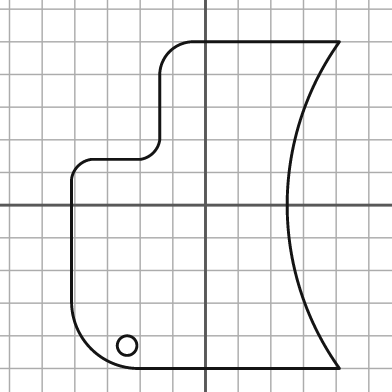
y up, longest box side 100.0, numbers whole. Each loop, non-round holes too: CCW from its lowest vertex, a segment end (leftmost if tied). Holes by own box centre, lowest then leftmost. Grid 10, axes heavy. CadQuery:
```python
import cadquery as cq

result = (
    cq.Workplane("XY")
    .moveTo(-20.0, -50.0)
    .lineTo(41.0, -50.0)
    .threePointArc((25.0, 0.0), (41.0, 50.0))
    .lineTo(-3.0, 50.0)
    .threePointArc((-11.0, 47.0), (-14.0, 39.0))
    .lineTo(-14.0, 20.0)
    .threePointArc((-16.0, 16.0), (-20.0, 14.0))
    .lineTo(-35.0, 14.0)
    .threePointArc((-39.0, 12.0), (-41.0, 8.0))
    .lineTo(-41.0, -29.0)
    .threePointArc((-35.0, -44.0), (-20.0, -50.0))
    .close()
    .moveTo(-24.0, -43.0)
    .circle(3.0)
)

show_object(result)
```